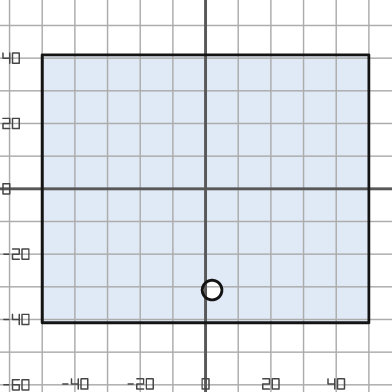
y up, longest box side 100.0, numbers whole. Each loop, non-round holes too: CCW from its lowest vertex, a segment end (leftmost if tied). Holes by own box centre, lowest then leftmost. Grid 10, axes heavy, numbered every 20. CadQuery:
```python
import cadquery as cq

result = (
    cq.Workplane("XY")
    .moveTo(-50.0, -41.0)
    .lineTo(50.0, -41.0)
    .lineTo(50.0, 41.0)
    .lineTo(-50.0, 41.0)
    .close()
    .moveTo(2.0, -31.0)
    .circle(3.0)
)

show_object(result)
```